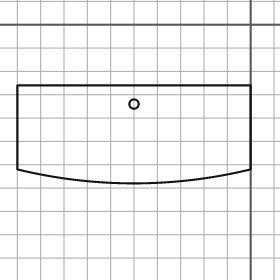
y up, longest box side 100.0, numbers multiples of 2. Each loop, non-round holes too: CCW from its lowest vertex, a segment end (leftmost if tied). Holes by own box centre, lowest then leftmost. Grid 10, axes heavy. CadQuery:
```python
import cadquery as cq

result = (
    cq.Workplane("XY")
    .moveTo(-100.0, -62.0)
    .threePointArc((-50.0, -68.0), (0.0, -62.0))
    .lineTo(0.0, -26.0)
    .lineTo(-100.0, -26.0)
    .close()
    .moveTo(-50.0, -34.0)
    .circle(2.0)
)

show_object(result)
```